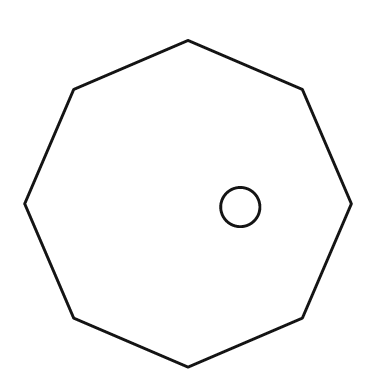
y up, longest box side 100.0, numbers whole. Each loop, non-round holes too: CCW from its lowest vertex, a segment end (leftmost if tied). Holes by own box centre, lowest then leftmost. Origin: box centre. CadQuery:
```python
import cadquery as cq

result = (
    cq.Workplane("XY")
    .moveTo(0.0, -50.0)
    .lineTo(35.0, -35.0)
    .lineTo(50.0, 0.0)
    .lineTo(35.0, 35.0)
    .lineTo(0.0, 50.0)
    .lineTo(-35.0, 35.0)
    .lineTo(-50.0, 0.0)
    .lineTo(-35.0, -35.0)
    .close()
    .moveTo(16.0, -1.0)
    .circle(6.0)
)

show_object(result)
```